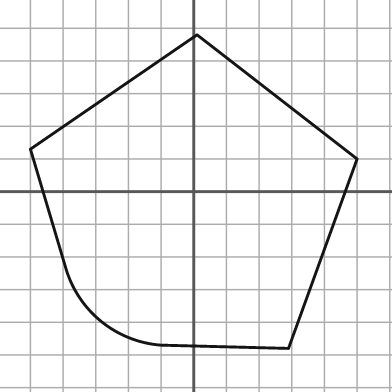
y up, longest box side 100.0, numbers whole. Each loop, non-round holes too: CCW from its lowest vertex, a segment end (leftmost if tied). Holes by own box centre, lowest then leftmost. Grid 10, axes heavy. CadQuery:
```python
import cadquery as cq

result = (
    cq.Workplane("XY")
    .moveTo(29.0, -48.0)
    .lineTo(50.0, 10.0)
    .lineTo(1.0, 48.0)
    .lineTo(-50.0, 13.0)
    .lineTo(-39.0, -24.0)
    .threePointArc((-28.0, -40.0), (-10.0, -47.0))
    .close()
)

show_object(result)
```